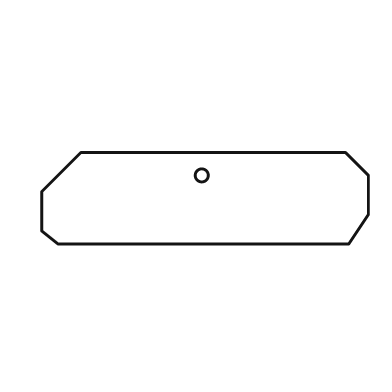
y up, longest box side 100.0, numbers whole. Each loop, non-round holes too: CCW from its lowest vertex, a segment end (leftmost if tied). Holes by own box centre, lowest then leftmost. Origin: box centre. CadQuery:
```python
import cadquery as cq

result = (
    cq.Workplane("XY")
    .moveTo(-45.0, -14.0)
    .lineTo(44.0, -14.0)
    .lineTo(50.0, -5.0)
    .lineTo(50.0, 7.0)
    .lineTo(43.0, 14.0)
    .lineTo(-38.0, 14.0)
    .lineTo(-50.0, 2.0)
    .lineTo(-50.0, -10.0)
    .close()
    .moveTo(-1.0, 7.0)
    .circle(2.0)
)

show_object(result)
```